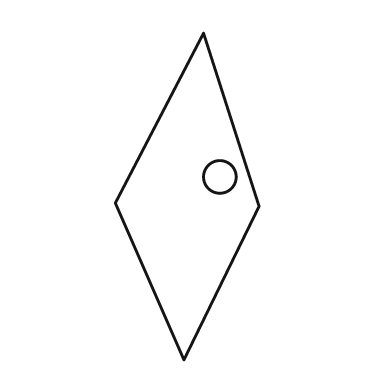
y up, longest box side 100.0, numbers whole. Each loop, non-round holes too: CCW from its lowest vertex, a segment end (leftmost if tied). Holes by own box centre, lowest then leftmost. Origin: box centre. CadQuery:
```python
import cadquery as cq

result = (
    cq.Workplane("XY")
    .moveTo(-1.0, -50.0)
    .lineTo(22.0, -3.0)
    .lineTo(5.0, 50.0)
    .lineTo(-22.0, -2.0)
    .close()
    .moveTo(10.0, 6.0)
    .circle(5.0)
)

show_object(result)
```